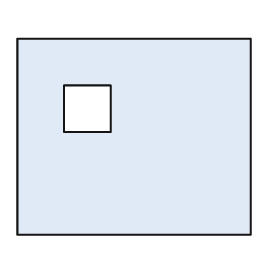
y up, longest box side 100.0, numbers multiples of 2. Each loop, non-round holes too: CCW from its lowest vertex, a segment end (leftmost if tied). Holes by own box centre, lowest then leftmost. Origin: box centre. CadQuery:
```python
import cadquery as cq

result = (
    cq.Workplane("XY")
    .moveTo(-50.0, -42.0)
    .lineTo(50.0, -42.0)
    .lineTo(50.0, 42.0)
    .lineTo(-50.0, 42.0)
    .close()
    .moveTo(-30.0, 2.0)
    .lineTo(-10.0, 2.0)
    .lineTo(-10.0, 22.0)
    .lineTo(-30.0, 22.0)
    .close()
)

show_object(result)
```